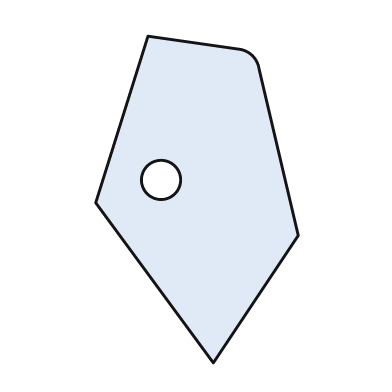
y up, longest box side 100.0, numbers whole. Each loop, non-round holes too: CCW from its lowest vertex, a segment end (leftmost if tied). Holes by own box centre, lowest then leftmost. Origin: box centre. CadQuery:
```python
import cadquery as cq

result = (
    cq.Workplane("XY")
    .moveTo(5.0, -50.0)
    .lineTo(31.0, -11.0)
    .lineTo(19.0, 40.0)
    .threePointArc((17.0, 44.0), (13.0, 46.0))
    .lineTo(-15.0, 50.0)
    .lineTo(-31.0, -1.0)
    .close()
    .moveTo(-11.0, 6.0)
    .circle(6.0)
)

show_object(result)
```